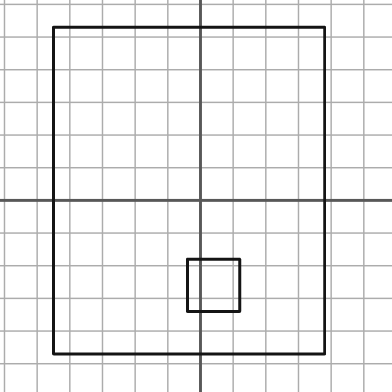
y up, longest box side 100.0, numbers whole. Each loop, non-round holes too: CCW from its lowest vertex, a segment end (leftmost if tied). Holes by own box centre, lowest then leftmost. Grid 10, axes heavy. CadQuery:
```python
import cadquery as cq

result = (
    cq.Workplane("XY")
    .moveTo(-45.0, -47.0)
    .lineTo(38.0, -47.0)
    .lineTo(38.0, 53.0)
    .lineTo(-45.0, 53.0)
    .close()
    .moveTo(-4.0, -34.0)
    .lineTo(12.0, -34.0)
    .lineTo(12.0, -18.0)
    .lineTo(-4.0, -18.0)
    .close()
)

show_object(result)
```